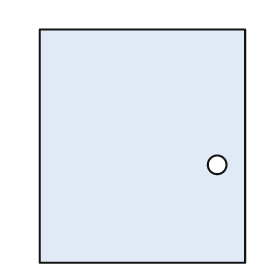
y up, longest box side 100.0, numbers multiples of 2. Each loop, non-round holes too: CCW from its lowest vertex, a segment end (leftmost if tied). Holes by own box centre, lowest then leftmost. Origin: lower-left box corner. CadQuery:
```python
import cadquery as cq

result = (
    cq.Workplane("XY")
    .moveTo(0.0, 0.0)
    .lineTo(88.0, 0.0)
    .lineTo(88.0, 100.0)
    .lineTo(0.0, 100.0)
    .close()
    .moveTo(76.0, 42.0)
    .circle(4.0)
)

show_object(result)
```